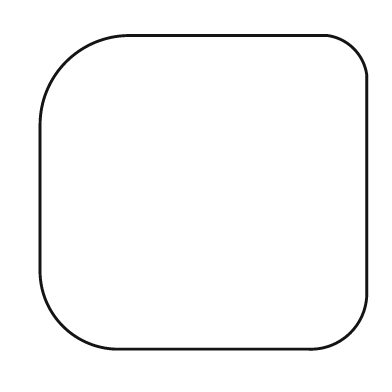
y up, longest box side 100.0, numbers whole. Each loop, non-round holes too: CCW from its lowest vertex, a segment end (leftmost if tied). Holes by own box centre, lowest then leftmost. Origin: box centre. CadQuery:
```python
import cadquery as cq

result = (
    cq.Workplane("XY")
    .moveTo(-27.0, -48.0)
    .lineTo(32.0, -48.0)
    .threePointArc((45.0, -43.0), (50.0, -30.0))
    .lineTo(50.0, 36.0)
    .threePointArc((46.0, 44.0), (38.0, 48.0))
    .lineTo(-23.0, 48.0)
    .threePointArc((-42.0, 40.0), (-50.0, 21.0))
    .lineTo(-50.0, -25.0)
    .threePointArc((-43.0, -41.0), (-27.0, -48.0))
    .close()
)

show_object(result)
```